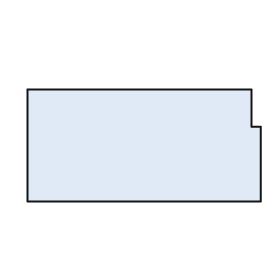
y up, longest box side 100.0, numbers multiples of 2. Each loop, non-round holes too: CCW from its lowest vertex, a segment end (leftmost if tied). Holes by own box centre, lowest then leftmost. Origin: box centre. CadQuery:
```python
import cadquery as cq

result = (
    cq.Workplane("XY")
    .moveTo(-50.0, -24.0)
    .lineTo(50.0, -24.0)
    .lineTo(50.0, 8.0)
    .lineTo(46.0, 8.0)
    .lineTo(46.0, 24.0)
    .lineTo(-50.0, 24.0)
    .close()
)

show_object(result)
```